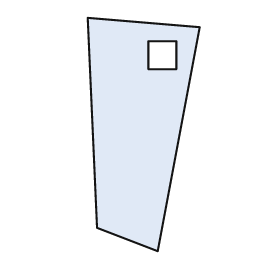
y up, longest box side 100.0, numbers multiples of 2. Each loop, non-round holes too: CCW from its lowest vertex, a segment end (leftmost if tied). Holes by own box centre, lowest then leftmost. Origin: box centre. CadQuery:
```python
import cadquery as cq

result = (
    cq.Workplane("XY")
    .moveTo(6.0, -50.0)
    .lineTo(24.0, 46.0)
    .lineTo(-24.0, 50.0)
    .lineTo(-20.0, -40.0)
    .close()
    .moveTo(2.0, 28.0)
    .lineTo(14.0, 28.0)
    .lineTo(14.0, 40.0)
    .lineTo(2.0, 40.0)
    .close()
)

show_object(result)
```